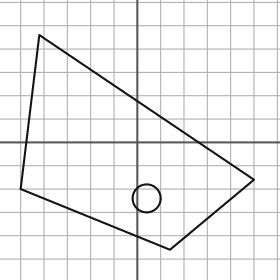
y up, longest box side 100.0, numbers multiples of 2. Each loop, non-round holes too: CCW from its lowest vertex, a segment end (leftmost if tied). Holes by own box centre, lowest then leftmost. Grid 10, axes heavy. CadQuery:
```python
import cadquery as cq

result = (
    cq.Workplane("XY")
    .moveTo(14.0, -46.0)
    .lineTo(50.0, -16.0)
    .lineTo(-42.0, 46.0)
    .lineTo(-50.0, -20.0)
    .close()
    .moveTo(4.0, -24.0)
    .circle(6.0)
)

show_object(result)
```